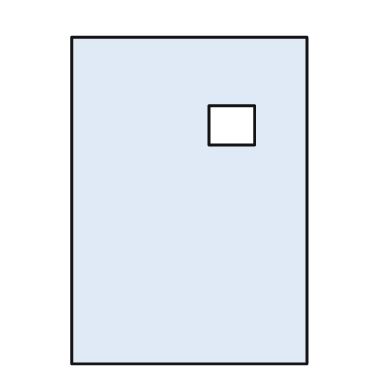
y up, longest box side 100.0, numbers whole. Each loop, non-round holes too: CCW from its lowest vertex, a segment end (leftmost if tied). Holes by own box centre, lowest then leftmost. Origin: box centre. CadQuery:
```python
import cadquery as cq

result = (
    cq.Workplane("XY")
    .moveTo(-36.0, -50.0)
    .lineTo(36.0, -50.0)
    .lineTo(36.0, 50.0)
    .lineTo(-36.0, 50.0)
    .close()
    .moveTo(6.0, 17.0)
    .lineTo(20.0, 17.0)
    .lineTo(20.0, 29.0)
    .lineTo(6.0, 29.0)
    .close()
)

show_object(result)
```